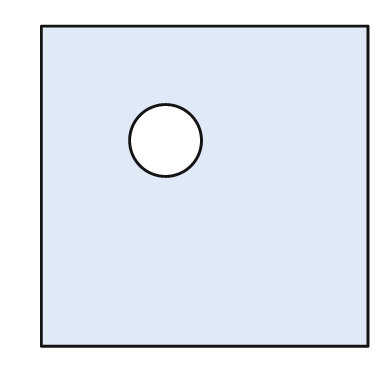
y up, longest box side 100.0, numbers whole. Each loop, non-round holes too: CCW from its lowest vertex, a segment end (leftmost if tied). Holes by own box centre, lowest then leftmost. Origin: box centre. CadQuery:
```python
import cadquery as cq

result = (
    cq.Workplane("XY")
    .moveTo(-50.0, -49.0)
    .lineTo(50.0, -49.0)
    .lineTo(50.0, 49.0)
    .lineTo(-50.0, 49.0)
    .close()
    .moveTo(-12.0, 14.0)
    .circle(11.0)
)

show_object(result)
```